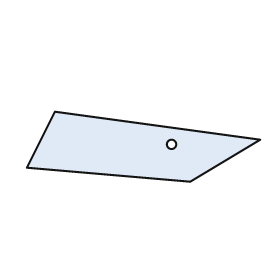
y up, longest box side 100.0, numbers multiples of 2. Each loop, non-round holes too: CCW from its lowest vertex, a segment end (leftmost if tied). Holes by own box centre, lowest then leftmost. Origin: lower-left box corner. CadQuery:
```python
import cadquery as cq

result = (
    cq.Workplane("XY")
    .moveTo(70.0, 0.0)
    .lineTo(100.0, 18.0)
    .lineTo(12.0, 30.0)
    .lineTo(0.0, 6.0)
    .close()
    .moveTo(62.0, 16.0)
    .circle(2.0)
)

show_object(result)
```